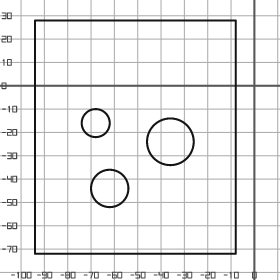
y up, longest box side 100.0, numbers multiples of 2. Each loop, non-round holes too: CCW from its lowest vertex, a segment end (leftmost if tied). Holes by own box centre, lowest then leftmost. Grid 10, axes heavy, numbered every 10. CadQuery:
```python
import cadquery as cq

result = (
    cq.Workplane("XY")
    .moveTo(-94.0, -72.0)
    .lineTo(-8.0, -72.0)
    .lineTo(-8.0, 28.0)
    .lineTo(-94.0, 28.0)
    .close()
    .moveTo(-62.0, -44.0)
    .circle(8.0)
    .moveTo(-36.0, -24.0)
    .circle(10.0)
    .moveTo(-68.0, -16.0)
    .circle(6.0)
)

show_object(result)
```